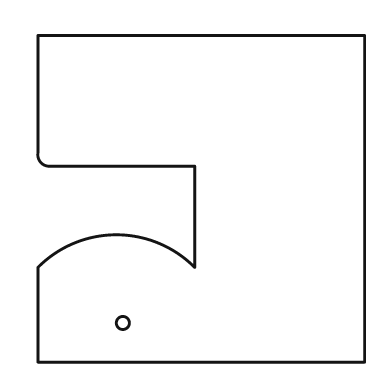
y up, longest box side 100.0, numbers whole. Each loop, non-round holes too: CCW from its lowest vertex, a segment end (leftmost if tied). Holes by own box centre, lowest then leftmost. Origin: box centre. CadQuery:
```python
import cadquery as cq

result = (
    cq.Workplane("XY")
    .moveTo(-50.0, -50.0)
    .lineTo(50.0, -50.0)
    .lineTo(50.0, 50.0)
    .lineTo(-50.0, 50.0)
    .lineTo(-50.0, 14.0)
    .threePointArc((-49.0, 11.0), (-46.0, 10.0))
    .lineTo(-2.0, 10.0)
    .lineTo(-2.0, -21.0)
    .threePointArc((-26.0, -11.0), (-50.0, -21.0))
    .close()
    .moveTo(-24.0, -38.0)
    .circle(2.0)
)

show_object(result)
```